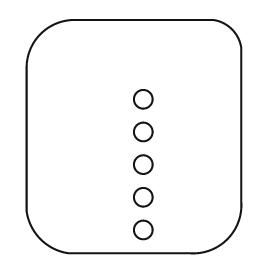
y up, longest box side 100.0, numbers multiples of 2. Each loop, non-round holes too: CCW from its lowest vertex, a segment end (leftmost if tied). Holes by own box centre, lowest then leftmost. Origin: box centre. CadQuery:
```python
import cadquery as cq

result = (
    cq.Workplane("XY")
    .moveTo(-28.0, -50.0)
    .lineTo(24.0, -50.0)
    .threePointArc((40.0, -44.0), (46.0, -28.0))
    .lineTo(46.0, 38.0)
    .threePointArc((42.0, 46.0), (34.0, 50.0))
    .lineTo(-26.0, 50.0)
    .threePointArc((-40.0, 44.0), (-46.0, 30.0))
    .lineTo(-46.0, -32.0)
    .threePointArc((-40.0, -44.0), (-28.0, -50.0))
    .close()
    .moveTo(4.0, -40.0)
    .circle(4.0)
    .moveTo(4.0, -26.0)
    .circle(4.0)
    .moveTo(4.0, -12.0)
    .circle(4.0)
    .moveTo(4.0, 2.0)
    .circle(4.0)
    .moveTo(4.0, 16.0)
    .circle(4.0)
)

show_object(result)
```